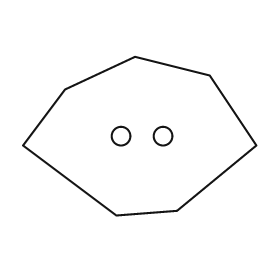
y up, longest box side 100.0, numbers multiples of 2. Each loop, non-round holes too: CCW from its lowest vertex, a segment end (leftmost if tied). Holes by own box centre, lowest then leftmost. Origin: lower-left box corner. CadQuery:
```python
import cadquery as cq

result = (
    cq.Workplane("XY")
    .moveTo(40.0, 0.0)
    .lineTo(66.0, 2.0)
    .lineTo(100.0, 30.0)
    .lineTo(80.0, 60.0)
    .lineTo(48.0, 68.0)
    .lineTo(18.0, 54.0)
    .lineTo(0.0, 30.0)
    .close()
    .moveTo(42.0, 34.0)
    .circle(4.0)
    .moveTo(60.0, 34.0)
    .circle(4.0)
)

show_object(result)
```